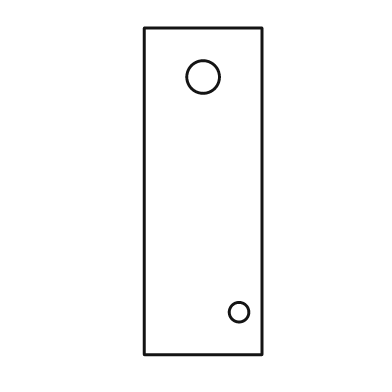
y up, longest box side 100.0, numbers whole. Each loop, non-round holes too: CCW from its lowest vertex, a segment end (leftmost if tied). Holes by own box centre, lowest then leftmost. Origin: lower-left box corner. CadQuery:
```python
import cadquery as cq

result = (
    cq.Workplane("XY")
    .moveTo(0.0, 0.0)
    .lineTo(36.0, 0.0)
    .lineTo(36.0, 100.0)
    .lineTo(0.0, 100.0)
    .close()
    .moveTo(29.0, 13.0)
    .circle(3.0)
    .moveTo(18.0, 85.0)
    .circle(5.0)
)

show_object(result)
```